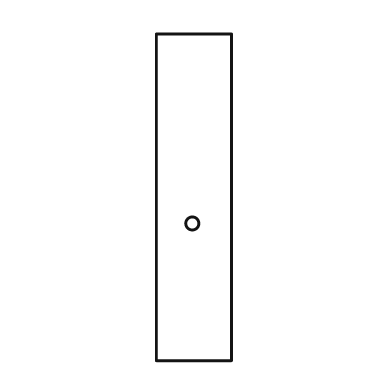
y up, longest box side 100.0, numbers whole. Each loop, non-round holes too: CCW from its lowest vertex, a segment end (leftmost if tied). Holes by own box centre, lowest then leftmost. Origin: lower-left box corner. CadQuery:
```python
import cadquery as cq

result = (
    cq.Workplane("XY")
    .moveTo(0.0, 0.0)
    .lineTo(23.0, 0.0)
    .lineTo(23.0, 100.0)
    .lineTo(0.0, 100.0)
    .close()
    .moveTo(11.0, 42.0)
    .circle(2.0)
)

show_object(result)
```